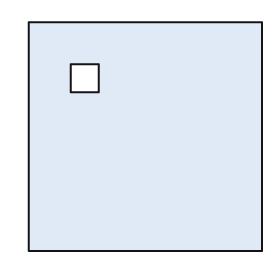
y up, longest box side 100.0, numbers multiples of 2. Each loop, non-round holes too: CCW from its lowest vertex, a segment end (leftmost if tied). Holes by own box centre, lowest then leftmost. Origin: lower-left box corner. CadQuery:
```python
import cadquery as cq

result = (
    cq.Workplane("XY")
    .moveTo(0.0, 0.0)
    .lineTo(100.0, 0.0)
    .lineTo(100.0, 98.0)
    .lineTo(0.0, 98.0)
    .close()
    .moveTo(18.0, 68.0)
    .lineTo(30.0, 68.0)
    .lineTo(30.0, 80.0)
    .lineTo(18.0, 80.0)
    .close()
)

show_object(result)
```